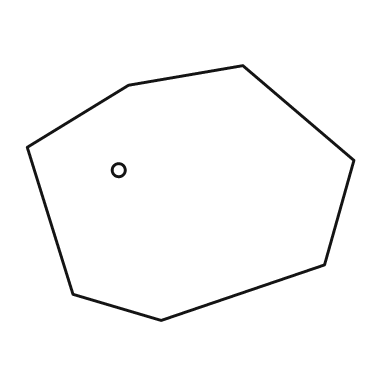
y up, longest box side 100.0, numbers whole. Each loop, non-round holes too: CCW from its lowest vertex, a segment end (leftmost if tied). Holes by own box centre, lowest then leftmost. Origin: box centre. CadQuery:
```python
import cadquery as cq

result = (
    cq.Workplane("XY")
    .moveTo(-9.0, -39.0)
    .lineTo(41.0, -22.0)
    .lineTo(50.0, 10.0)
    .lineTo(16.0, 39.0)
    .lineTo(-19.0, 33.0)
    .lineTo(-50.0, 14.0)
    .lineTo(-36.0, -31.0)
    .close()
    .moveTo(-22.0, 7.0)
    .circle(2.0)
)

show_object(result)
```